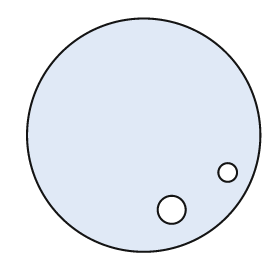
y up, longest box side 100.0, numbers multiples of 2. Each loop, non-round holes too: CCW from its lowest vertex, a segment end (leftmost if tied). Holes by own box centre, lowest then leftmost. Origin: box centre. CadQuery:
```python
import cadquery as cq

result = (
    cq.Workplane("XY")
    .moveTo(0.0, 0.0)
    .circle(50.0)
    .moveTo(12.0, -32.0)
    .circle(6.0)
    .moveTo(36.0, -16.0)
    .circle(4.0)
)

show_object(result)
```